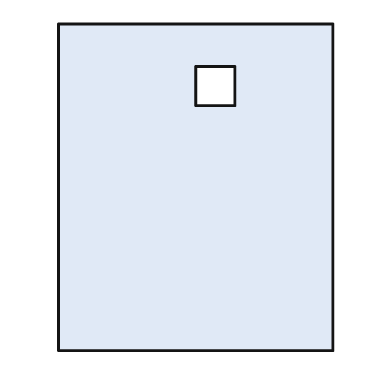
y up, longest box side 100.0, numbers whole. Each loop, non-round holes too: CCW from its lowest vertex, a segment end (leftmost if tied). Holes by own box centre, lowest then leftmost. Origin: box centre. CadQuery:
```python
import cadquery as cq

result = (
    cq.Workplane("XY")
    .moveTo(-42.0, -50.0)
    .lineTo(42.0, -50.0)
    .lineTo(42.0, 50.0)
    .lineTo(-42.0, 50.0)
    .close()
    .moveTo(0.0, 25.0)
    .lineTo(12.0, 25.0)
    .lineTo(12.0, 37.0)
    .lineTo(0.0, 37.0)
    .close()
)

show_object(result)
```